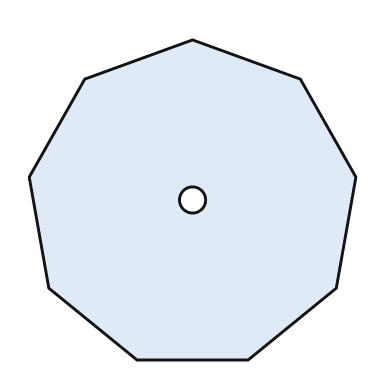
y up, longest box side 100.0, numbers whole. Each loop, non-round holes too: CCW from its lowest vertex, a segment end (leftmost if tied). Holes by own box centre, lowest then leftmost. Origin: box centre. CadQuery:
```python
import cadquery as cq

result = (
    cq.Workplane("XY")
    .moveTo(-17.0, -49.0)
    .lineTo(17.0, -49.0)
    .lineTo(44.0, -27.0)
    .lineTo(50.0, 7.0)
    .lineTo(33.0, 37.0)
    .lineTo(0.0, 49.0)
    .lineTo(-33.0, 37.0)
    .lineTo(-50.0, 7.0)
    .lineTo(-44.0, -27.0)
    .close()
    .moveTo(0.0, 0.0)
    .circle(4.0)
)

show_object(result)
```